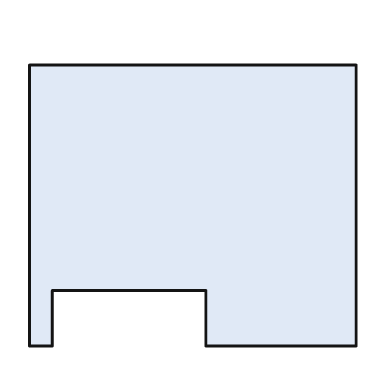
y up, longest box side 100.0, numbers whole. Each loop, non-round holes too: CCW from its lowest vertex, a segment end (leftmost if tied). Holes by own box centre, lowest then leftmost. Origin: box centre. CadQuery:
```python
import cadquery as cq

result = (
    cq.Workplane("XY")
    .moveTo(-50.0, -43.0)
    .lineTo(-43.0, -43.0)
    .lineTo(-43.0, -26.0)
    .lineTo(4.0, -26.0)
    .lineTo(4.0, -43.0)
    .lineTo(50.0, -43.0)
    .lineTo(50.0, 43.0)
    .lineTo(-50.0, 43.0)
    .close()
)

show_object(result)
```